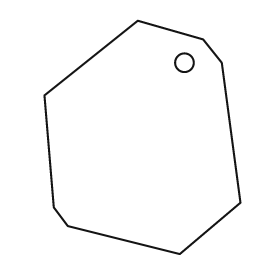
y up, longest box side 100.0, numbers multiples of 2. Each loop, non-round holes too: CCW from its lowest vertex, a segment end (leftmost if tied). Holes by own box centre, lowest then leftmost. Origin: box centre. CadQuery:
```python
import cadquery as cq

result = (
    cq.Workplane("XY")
    .moveTo(16.0, -50.0)
    .lineTo(42.0, -28.0)
    .lineTo(34.0, 32.0)
    .lineTo(26.0, 42.0)
    .lineTo(-2.0, 50.0)
    .lineTo(-42.0, 18.0)
    .lineTo(-38.0, -30.0)
    .lineTo(-32.0, -38.0)
    .close()
    .moveTo(18.0, 32.0)
    .circle(4.0)
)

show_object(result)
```